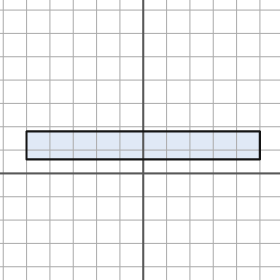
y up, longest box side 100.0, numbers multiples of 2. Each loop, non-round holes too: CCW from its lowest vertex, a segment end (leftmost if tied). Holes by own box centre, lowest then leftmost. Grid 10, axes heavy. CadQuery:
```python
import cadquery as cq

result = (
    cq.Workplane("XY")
    .moveTo(-50.0, 6.0)
    .lineTo(50.0, 6.0)
    .lineTo(50.0, 18.0)
    .lineTo(-50.0, 18.0)
    .close()
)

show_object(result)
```